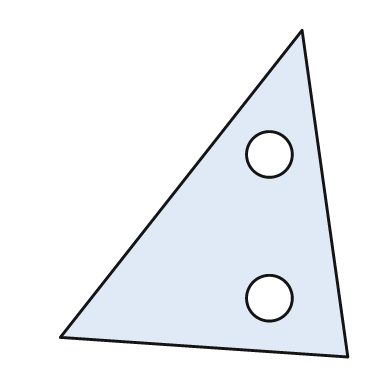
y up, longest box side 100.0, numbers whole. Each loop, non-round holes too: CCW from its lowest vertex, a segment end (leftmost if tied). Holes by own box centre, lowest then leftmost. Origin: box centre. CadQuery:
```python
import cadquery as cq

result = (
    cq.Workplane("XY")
    .moveTo(44.0, -50.0)
    .lineTo(30.0, 50.0)
    .lineTo(-44.0, -44.0)
    .close()
    .moveTo(20.0, -32.0)
    .circle(7.0)
    .moveTo(20.0, 12.0)
    .circle(7.0)
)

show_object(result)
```